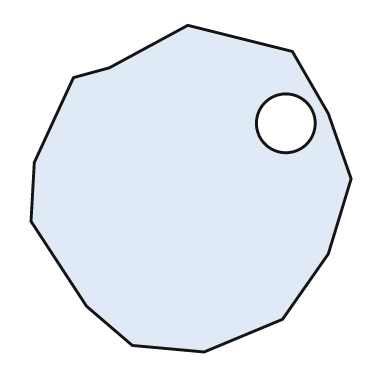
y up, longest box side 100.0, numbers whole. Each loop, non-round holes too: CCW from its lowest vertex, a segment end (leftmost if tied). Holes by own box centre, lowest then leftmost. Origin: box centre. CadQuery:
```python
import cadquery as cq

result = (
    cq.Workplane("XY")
    .moveTo(4.0, -50.0)
    .lineTo(28.0, -40.0)
    .lineTo(42.0, -20.0)
    .lineTo(49.0, 3.0)
    .lineTo(42.0, 23.0)
    .lineTo(31.0, 42.0)
    .lineTo(-1.0, 50.0)
    .lineTo(-25.0, 37.0)
    .lineTo(-36.0, 34.0)
    .lineTo(-48.0, 8.0)
    .lineTo(-49.0, -10.0)
    .lineTo(-32.0, -36.0)
    .lineTo(-18.0, -48.0)
    .close()
    .moveTo(29.0, 20.0)
    .circle(9.0)
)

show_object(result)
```